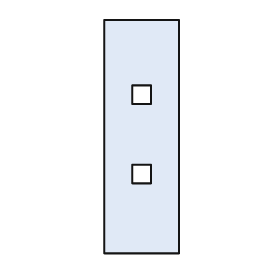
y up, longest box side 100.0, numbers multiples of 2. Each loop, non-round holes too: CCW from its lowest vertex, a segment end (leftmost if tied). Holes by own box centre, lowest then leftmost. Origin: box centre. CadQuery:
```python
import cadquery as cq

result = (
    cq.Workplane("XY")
    .moveTo(-16.0, -50.0)
    .lineTo(16.0, -50.0)
    .lineTo(16.0, 50.0)
    .lineTo(-16.0, 50.0)
    .close()
    .moveTo(-4.0, -20.0)
    .lineTo(4.0, -20.0)
    .lineTo(4.0, -12.0)
    .lineTo(-4.0, -12.0)
    .close()
    .moveTo(-4.0, 14.0)
    .lineTo(4.0, 14.0)
    .lineTo(4.0, 22.0)
    .lineTo(-4.0, 22.0)
    .close()
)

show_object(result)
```